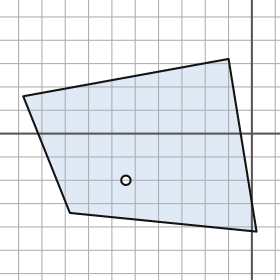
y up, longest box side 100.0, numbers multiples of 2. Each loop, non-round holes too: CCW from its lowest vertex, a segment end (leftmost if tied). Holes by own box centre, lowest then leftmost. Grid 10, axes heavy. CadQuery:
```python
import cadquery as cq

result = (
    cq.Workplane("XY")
    .moveTo(2.0, -42.0)
    .lineTo(-10.0, 32.0)
    .lineTo(-98.0, 16.0)
    .lineTo(-78.0, -34.0)
    .close()
    .moveTo(-54.0, -20.0)
    .circle(2.0)
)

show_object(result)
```